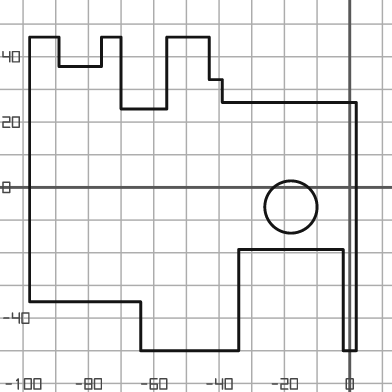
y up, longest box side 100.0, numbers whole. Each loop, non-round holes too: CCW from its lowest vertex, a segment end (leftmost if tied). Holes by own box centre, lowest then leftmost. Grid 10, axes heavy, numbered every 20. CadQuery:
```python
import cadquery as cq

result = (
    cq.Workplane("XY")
    .moveTo(-64.0, -50.0)
    .lineTo(-34.0, -50.0)
    .lineTo(-34.0, -19.0)
    .lineTo(-2.0, -19.0)
    .lineTo(-2.0, -50.0)
    .lineTo(2.0, -50.0)
    .lineTo(2.0, 26.0)
    .lineTo(-39.0, 26.0)
    .lineTo(-39.0, 33.0)
    .lineTo(-43.0, 33.0)
    .lineTo(-43.0, 46.0)
    .lineTo(-56.0, 46.0)
    .lineTo(-56.0, 24.0)
    .lineTo(-70.0, 24.0)
    .lineTo(-70.0, 46.0)
    .lineTo(-76.0, 46.0)
    .lineTo(-76.0, 37.0)
    .lineTo(-89.0, 37.0)
    .lineTo(-89.0, 46.0)
    .lineTo(-98.0, 46.0)
    .lineTo(-98.0, -35.0)
    .lineTo(-64.0, -35.0)
    .close()
    .moveTo(-18.0, -6.0)
    .circle(8.0)
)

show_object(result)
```